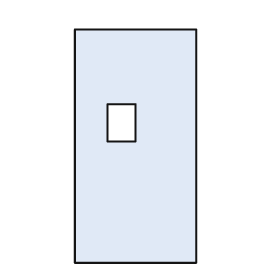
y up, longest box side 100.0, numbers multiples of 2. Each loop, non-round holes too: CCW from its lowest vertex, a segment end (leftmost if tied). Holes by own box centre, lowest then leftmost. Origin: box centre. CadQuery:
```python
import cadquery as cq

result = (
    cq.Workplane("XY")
    .moveTo(-26.0, -50.0)
    .lineTo(26.0, -50.0)
    .lineTo(26.0, 50.0)
    .lineTo(-26.0, 50.0)
    .close()
    .moveTo(-12.0, 2.0)
    .lineTo(0.0, 2.0)
    .lineTo(0.0, 18.0)
    .lineTo(-12.0, 18.0)
    .close()
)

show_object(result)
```